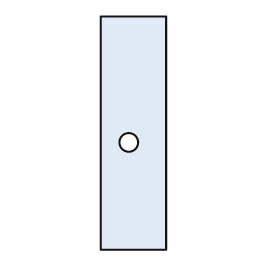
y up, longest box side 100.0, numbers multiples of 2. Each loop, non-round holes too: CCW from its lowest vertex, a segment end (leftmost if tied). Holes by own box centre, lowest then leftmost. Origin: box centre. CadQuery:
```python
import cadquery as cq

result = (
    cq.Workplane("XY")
    .moveTo(-14.0, -50.0)
    .lineTo(14.0, -50.0)
    .lineTo(14.0, 50.0)
    .lineTo(-14.0, 50.0)
    .close()
    .moveTo(-2.0, -4.0)
    .circle(4.0)
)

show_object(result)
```